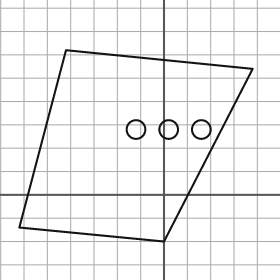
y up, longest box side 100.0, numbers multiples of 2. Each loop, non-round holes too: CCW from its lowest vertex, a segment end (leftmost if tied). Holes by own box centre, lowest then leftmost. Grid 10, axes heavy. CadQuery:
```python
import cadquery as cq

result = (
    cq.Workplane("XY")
    .moveTo(0.0, -20.0)
    .lineTo(38.0, 54.0)
    .lineTo(-42.0, 62.0)
    .lineTo(-62.0, -14.0)
    .close()
    .moveTo(-12.0, 28.0)
    .circle(4.0)
    .moveTo(2.0, 28.0)
    .circle(4.0)
    .moveTo(16.0, 28.0)
    .circle(4.0)
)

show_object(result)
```